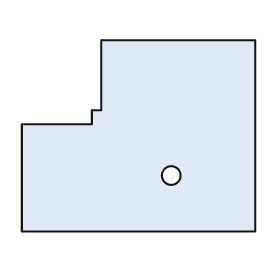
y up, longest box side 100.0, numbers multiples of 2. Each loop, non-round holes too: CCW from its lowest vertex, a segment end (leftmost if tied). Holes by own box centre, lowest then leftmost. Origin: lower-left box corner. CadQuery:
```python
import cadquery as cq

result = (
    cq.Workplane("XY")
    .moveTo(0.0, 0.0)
    .lineTo(100.0, 0.0)
    .lineTo(100.0, 82.0)
    .lineTo(34.0, 82.0)
    .lineTo(34.0, 52.0)
    .lineTo(30.0, 52.0)
    .lineTo(30.0, 46.0)
    .lineTo(0.0, 46.0)
    .close()
    .moveTo(64.0, 24.0)
    .circle(4.0)
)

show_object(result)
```